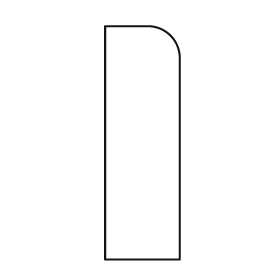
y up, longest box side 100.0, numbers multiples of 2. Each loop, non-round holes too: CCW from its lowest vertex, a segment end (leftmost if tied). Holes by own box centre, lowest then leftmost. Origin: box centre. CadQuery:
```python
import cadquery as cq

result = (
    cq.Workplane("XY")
    .moveTo(-16.0, -50.0)
    .lineTo(16.0, -50.0)
    .lineTo(16.0, 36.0)
    .threePointArc((12.0, 46.0), (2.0, 50.0))
    .lineTo(-16.0, 50.0)
    .close()
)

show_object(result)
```